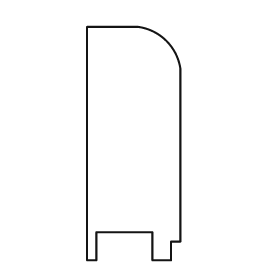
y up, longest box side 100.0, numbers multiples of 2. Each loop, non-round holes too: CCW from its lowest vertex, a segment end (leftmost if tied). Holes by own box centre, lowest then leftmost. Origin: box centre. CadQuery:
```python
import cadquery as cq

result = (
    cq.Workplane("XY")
    .moveTo(-20.0, -50.0)
    .lineTo(-16.0, -50.0)
    .lineTo(-16.0, -38.0)
    .lineTo(8.0, -38.0)
    .lineTo(8.0, -50.0)
    .lineTo(16.0, -50.0)
    .lineTo(16.0, -42.0)
    .lineTo(20.0, -42.0)
    .lineTo(20.0, 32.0)
    .threePointArc((14.0, 44.0), (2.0, 50.0))
    .lineTo(-20.0, 50.0)
    .close()
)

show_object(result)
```